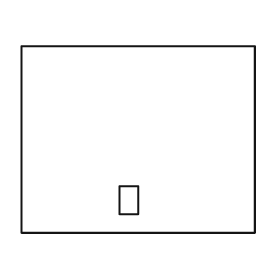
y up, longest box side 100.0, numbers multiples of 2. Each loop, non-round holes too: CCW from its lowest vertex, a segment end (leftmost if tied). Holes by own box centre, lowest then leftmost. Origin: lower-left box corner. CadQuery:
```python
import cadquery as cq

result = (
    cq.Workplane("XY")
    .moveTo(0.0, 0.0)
    .lineTo(100.0, 0.0)
    .lineTo(100.0, 80.0)
    .lineTo(0.0, 80.0)
    .close()
    .moveTo(42.0, 8.0)
    .lineTo(50.0, 8.0)
    .lineTo(50.0, 20.0)
    .lineTo(42.0, 20.0)
    .close()
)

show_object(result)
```